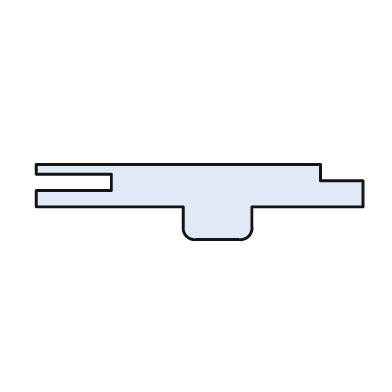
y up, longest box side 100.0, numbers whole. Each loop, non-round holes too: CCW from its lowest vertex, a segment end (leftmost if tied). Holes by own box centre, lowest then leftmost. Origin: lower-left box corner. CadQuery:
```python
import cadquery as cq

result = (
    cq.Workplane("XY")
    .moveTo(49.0, 0.0)
    .lineTo(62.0, 0.0)
    .threePointArc((65.0, 1.0), (66.0, 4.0))
    .lineTo(66.0, 10.0)
    .lineTo(100.0, 10.0)
    .lineTo(100.0, 18.0)
    .lineTo(87.0, 18.0)
    .lineTo(87.0, 23.0)
    .lineTo(0.0, 23.0)
    .lineTo(0.0, 20.0)
    .lineTo(23.0, 20.0)
    .lineTo(23.0, 15.0)
    .lineTo(0.0, 15.0)
    .lineTo(0.0, 10.0)
    .lineTo(45.0, 10.0)
    .lineTo(45.0, 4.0)
    .threePointArc((46.0, 1.0), (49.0, 0.0))
    .close()
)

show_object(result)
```